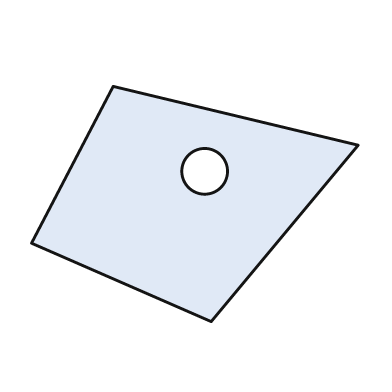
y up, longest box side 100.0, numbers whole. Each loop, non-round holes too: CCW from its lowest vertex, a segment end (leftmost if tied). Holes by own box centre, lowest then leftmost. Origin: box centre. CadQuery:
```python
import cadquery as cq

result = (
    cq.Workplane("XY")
    .moveTo(5.0, -36.0)
    .lineTo(50.0, 18.0)
    .lineTo(-25.0, 36.0)
    .lineTo(-50.0, -12.0)
    .close()
    .moveTo(3.0, 10.0)
    .circle(7.0)
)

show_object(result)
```